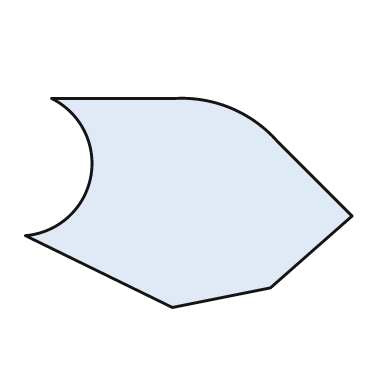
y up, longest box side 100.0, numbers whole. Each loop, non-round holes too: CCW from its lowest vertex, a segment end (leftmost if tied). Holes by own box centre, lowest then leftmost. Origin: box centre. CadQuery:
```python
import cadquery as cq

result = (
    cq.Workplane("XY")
    .moveTo(-5.0, -32.0)
    .lineTo(25.0, -26.0)
    .lineTo(50.0, -4.0)
    .lineTo(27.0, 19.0)
    .threePointArc((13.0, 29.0), (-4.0, 32.0))
    .lineTo(-42.0, 32.0)
    .threePointArc((-30.0, 8.0), (-50.0, -10.0))
    .close()
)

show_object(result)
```